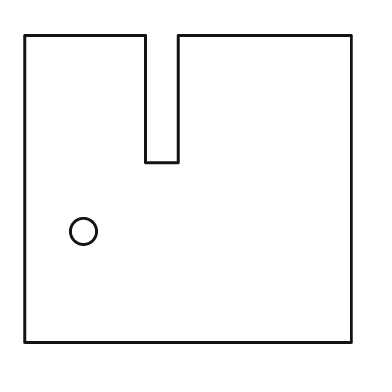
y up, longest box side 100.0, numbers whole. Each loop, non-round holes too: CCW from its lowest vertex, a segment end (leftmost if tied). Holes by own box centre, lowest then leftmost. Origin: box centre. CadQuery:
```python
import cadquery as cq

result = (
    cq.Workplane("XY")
    .moveTo(-50.0, -47.0)
    .lineTo(50.0, -47.0)
    .lineTo(50.0, 47.0)
    .lineTo(-3.0, 47.0)
    .lineTo(-3.0, 8.0)
    .lineTo(-13.0, 8.0)
    .lineTo(-13.0, 47.0)
    .lineTo(-50.0, 47.0)
    .close()
    .moveTo(-32.0, -13.0)
    .circle(4.0)
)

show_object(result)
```